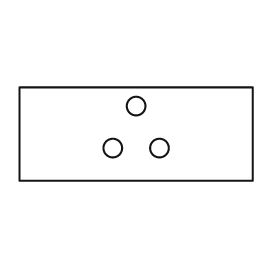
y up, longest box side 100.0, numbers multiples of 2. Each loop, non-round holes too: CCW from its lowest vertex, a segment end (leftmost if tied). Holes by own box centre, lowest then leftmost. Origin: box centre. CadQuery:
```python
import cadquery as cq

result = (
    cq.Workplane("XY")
    .moveTo(-50.0, -20.0)
    .lineTo(50.0, -20.0)
    .lineTo(50.0, 20.0)
    .lineTo(-50.0, 20.0)
    .close()
    .moveTo(-10.0, -6.0)
    .circle(4.0)
    .moveTo(10.0, -6.0)
    .circle(4.0)
    .moveTo(0.0, 12.0)
    .circle(4.0)
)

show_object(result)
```